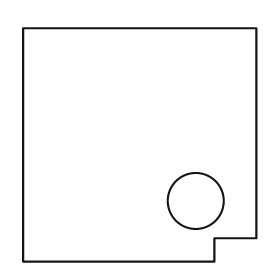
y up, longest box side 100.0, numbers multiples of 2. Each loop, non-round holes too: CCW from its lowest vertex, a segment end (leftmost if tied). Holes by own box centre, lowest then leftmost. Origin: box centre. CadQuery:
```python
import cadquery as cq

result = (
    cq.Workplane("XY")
    .moveTo(-50.0, -50.0)
    .lineTo(32.0, -50.0)
    .lineTo(32.0, -40.0)
    .lineTo(50.0, -40.0)
    .lineTo(50.0, 50.0)
    .lineTo(-50.0, 50.0)
    .close()
    .moveTo(24.0, -24.0)
    .circle(12.0)
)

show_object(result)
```